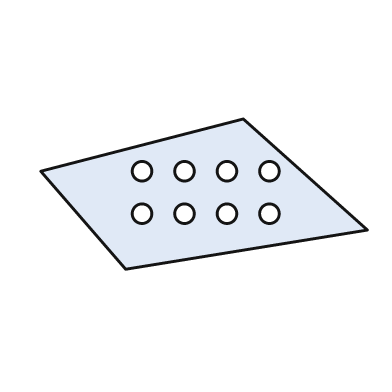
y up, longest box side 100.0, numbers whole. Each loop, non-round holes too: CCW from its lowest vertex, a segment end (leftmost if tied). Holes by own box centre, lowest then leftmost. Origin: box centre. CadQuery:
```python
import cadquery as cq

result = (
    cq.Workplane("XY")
    .moveTo(-24.0, -23.0)
    .lineTo(50.0, -11.0)
    .lineTo(12.0, 23.0)
    .lineTo(-50.0, 7.0)
    .close()
    .moveTo(-19.0, -6.0)
    .circle(3.0)
    .moveTo(-6.0, -6.0)
    .circle(3.0)
    .moveTo(7.0, -6.0)
    .circle(3.0)
    .moveTo(20.0, -6.0)
    .circle(3.0)
    .moveTo(-19.0, 7.0)
    .circle(3.0)
    .moveTo(-6.0, 7.0)
    .circle(3.0)
    .moveTo(7.0, 7.0)
    .circle(3.0)
    .moveTo(20.0, 7.0)
    .circle(3.0)
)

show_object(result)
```